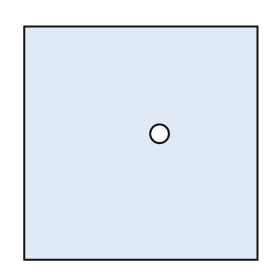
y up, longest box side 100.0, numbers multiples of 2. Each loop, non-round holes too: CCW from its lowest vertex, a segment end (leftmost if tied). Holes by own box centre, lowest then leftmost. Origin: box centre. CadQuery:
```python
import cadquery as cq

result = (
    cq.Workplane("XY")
    .moveTo(-50.0, -50.0)
    .lineTo(50.0, -50.0)
    .lineTo(50.0, 50.0)
    .lineTo(-50.0, 50.0)
    .close()
    .moveTo(8.0, 4.0)
    .circle(4.0)
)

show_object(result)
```